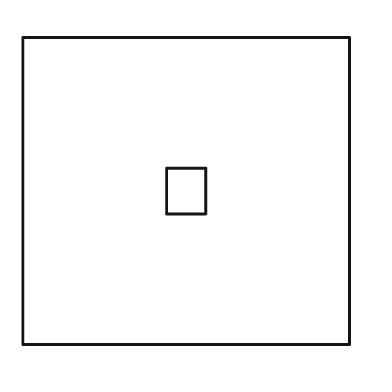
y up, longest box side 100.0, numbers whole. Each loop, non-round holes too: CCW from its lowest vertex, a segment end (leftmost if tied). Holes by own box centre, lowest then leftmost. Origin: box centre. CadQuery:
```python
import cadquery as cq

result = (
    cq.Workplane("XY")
    .moveTo(-50.0, -47.0)
    .lineTo(50.0, -47.0)
    .lineTo(50.0, 47.0)
    .lineTo(-50.0, 47.0)
    .close()
    .moveTo(-6.0, -7.0)
    .lineTo(6.0, -7.0)
    .lineTo(6.0, 7.0)
    .lineTo(-6.0, 7.0)
    .close()
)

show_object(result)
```